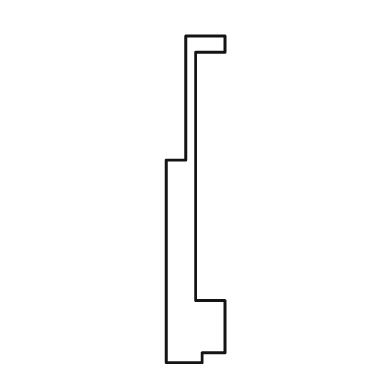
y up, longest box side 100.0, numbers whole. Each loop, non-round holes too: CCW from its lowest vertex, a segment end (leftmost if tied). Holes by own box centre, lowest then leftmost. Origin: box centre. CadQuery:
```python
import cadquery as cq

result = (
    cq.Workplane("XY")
    .moveTo(-9.0, -50.0)
    .lineTo(2.0, -50.0)
    .lineTo(2.0, -47.0)
    .lineTo(9.0, -47.0)
    .lineTo(9.0, -31.0)
    .lineTo(0.0, -31.0)
    .lineTo(0.0, 45.0)
    .lineTo(9.0, 45.0)
    .lineTo(9.0, 50.0)
    .lineTo(-3.0, 50.0)
    .lineTo(-3.0, 12.0)
    .lineTo(-9.0, 12.0)
    .close()
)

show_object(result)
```